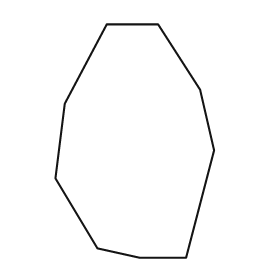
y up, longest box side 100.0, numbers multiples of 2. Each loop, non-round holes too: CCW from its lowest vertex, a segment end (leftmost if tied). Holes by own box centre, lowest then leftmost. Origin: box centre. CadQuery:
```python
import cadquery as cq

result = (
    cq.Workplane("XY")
    .moveTo(2.0, -50.0)
    .lineTo(22.0, -50.0)
    .lineTo(34.0, -4.0)
    .lineTo(28.0, 22.0)
    .lineTo(10.0, 50.0)
    .lineTo(-12.0, 50.0)
    .lineTo(-30.0, 16.0)
    .lineTo(-34.0, -16.0)
    .lineTo(-16.0, -46.0)
    .close()
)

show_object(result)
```